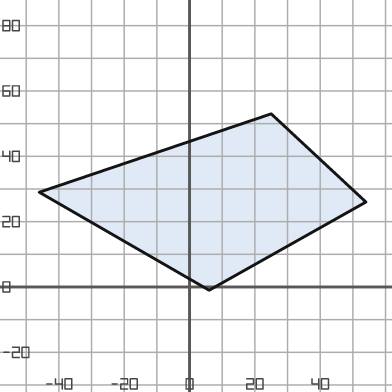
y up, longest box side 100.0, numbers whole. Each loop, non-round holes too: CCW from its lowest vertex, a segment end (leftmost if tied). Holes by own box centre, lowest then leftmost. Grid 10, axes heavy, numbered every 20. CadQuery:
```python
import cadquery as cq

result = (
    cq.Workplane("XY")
    .moveTo(6.0, -1.0)
    .lineTo(54.0, 26.0)
    .lineTo(25.0, 53.0)
    .lineTo(-46.0, 29.0)
    .close()
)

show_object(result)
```